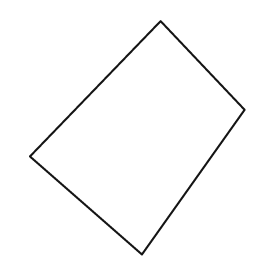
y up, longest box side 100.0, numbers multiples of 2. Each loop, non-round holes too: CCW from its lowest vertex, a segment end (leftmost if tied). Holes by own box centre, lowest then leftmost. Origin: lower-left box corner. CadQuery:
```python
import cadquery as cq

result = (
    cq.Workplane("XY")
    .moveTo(48.0, 0.0)
    .lineTo(92.0, 62.0)
    .lineTo(56.0, 100.0)
    .lineTo(0.0, 42.0)
    .close()
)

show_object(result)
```